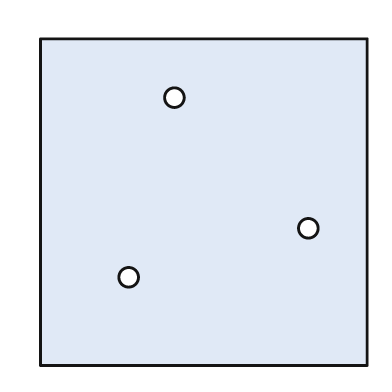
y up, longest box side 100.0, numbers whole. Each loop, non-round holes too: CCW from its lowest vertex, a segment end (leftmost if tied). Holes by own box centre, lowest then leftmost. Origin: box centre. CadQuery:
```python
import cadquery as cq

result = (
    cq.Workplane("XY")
    .moveTo(-50.0, -50.0)
    .lineTo(50.0, -50.0)
    .lineTo(50.0, 50.0)
    .lineTo(-50.0, 50.0)
    .close()
    .moveTo(-23.0, -23.0)
    .circle(3.0)
    .moveTo(32.0, -8.0)
    .circle(3.0)
    .moveTo(-9.0, 32.0)
    .circle(3.0)
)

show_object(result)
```